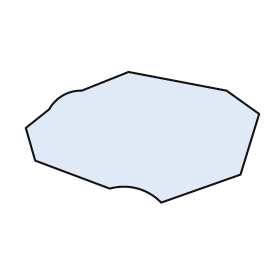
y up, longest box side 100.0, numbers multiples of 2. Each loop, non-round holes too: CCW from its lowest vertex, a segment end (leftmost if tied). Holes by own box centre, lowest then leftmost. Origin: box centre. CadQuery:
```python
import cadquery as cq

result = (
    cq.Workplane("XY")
    .moveTo(8.0, -28.0)
    .lineTo(42.0, -16.0)
    .lineTo(50.0, 10.0)
    .lineTo(36.0, 20.0)
    .lineTo(-6.0, 28.0)
    .lineTo(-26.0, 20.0)
    .threePointArc((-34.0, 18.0), (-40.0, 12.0))
    .lineTo(-50.0, 4.0)
    .lineTo(-46.0, -10.0)
    .lineTo(-14.0, -22.0)
    .threePointArc((-2.0, -22.0), (8.0, -28.0))
    .close()
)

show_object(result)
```